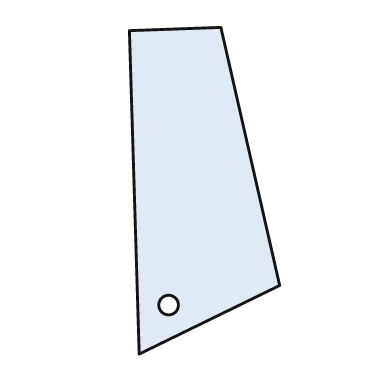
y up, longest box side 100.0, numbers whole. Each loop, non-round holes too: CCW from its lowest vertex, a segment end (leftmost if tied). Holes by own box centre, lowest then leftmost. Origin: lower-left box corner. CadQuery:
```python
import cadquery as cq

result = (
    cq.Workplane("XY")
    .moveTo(3.0, 0.0)
    .lineTo(46.0, 21.0)
    .lineTo(28.0, 100.0)
    .lineTo(0.0, 99.0)
    .close()
    .moveTo(12.0, 15.0)
    .circle(3.0)
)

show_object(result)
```